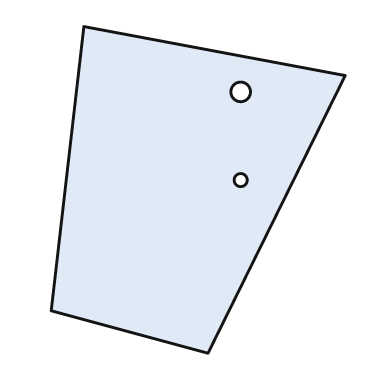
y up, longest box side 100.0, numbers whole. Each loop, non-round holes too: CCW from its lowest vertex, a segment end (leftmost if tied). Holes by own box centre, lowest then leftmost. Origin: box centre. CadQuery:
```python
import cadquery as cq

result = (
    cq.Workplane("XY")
    .moveTo(3.0, -50.0)
    .lineTo(45.0, 35.0)
    .lineTo(-35.0, 50.0)
    .lineTo(-45.0, -37.0)
    .close()
    .moveTo(13.0, 3.0)
    .circle(2.0)
    .moveTo(13.0, 30.0)
    .circle(3.0)
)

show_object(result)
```